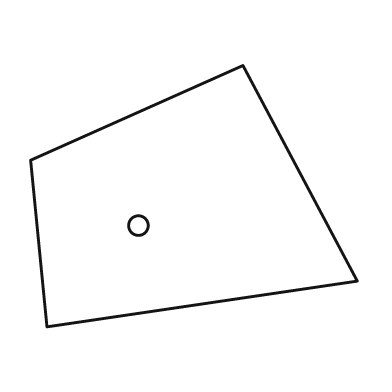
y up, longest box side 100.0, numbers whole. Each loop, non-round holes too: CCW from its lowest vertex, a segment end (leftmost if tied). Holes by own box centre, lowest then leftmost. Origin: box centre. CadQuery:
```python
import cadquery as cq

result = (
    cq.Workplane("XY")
    .moveTo(-45.0, -40.0)
    .lineTo(50.0, -26.0)
    .lineTo(15.0, 40.0)
    .lineTo(-50.0, 11.0)
    .close()
    .moveTo(-17.0, -9.0)
    .circle(3.0)
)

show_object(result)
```